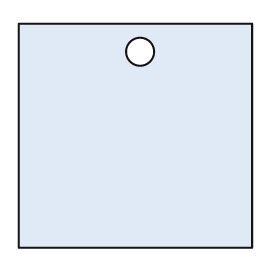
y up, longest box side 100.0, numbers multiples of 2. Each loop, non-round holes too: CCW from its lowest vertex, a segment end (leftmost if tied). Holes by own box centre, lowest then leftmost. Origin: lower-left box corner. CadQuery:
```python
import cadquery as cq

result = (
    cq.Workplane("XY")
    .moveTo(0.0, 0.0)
    .lineTo(100.0, 0.0)
    .lineTo(100.0, 96.0)
    .lineTo(0.0, 96.0)
    .close()
    .moveTo(52.0, 84.0)
    .circle(6.0)
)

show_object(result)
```